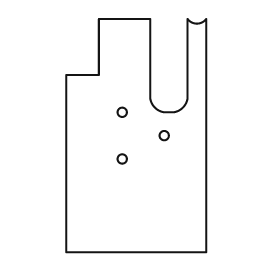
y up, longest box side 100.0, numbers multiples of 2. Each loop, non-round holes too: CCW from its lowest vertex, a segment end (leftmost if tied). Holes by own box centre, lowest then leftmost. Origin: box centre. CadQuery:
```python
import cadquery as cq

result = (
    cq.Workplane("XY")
    .moveTo(-30.0, -50.0)
    .lineTo(30.0, -50.0)
    .lineTo(30.0, 50.0)
    .threePointArc((26.0, 48.0), (22.0, 50.0))
    .lineTo(22.0, 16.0)
    .threePointArc((20.0, 12.0), (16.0, 10.0))
    .lineTo(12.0, 10.0)
    .threePointArc((8.0, 12.0), (6.0, 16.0))
    .lineTo(6.0, 50.0)
    .lineTo(-16.0, 50.0)
    .lineTo(-16.0, 26.0)
    .lineTo(-30.0, 26.0)
    .close()
    .moveTo(-6.0, -10.0)
    .circle(2.0)
    .moveTo(12.0, 0.0)
    .circle(2.0)
    .moveTo(-6.0, 10.0)
    .circle(2.0)
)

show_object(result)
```